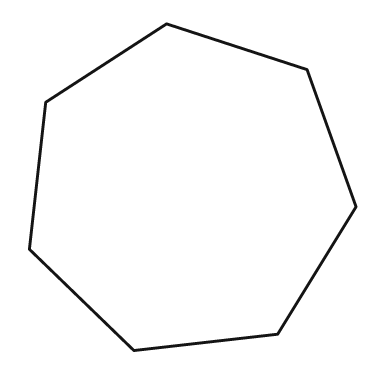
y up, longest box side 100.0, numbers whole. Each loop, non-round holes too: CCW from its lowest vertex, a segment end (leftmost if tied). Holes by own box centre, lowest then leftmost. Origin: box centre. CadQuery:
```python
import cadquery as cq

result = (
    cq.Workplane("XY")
    .moveTo(-18.0, -50.0)
    .lineTo(26.0, -45.0)
    .lineTo(50.0, -6.0)
    .lineTo(35.0, 36.0)
    .lineTo(-8.0, 50.0)
    .lineTo(-45.0, 26.0)
    .lineTo(-50.0, -19.0)
    .close()
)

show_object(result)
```